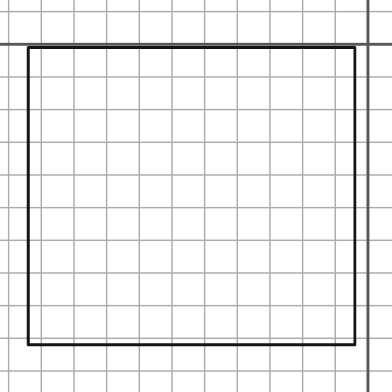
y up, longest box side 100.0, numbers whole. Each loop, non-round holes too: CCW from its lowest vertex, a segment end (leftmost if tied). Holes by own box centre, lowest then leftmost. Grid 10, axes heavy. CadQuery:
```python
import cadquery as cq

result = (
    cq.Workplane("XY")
    .moveTo(-104.0, -92.0)
    .lineTo(-4.0, -92.0)
    .lineTo(-4.0, -1.0)
    .lineTo(-104.0, -1.0)
    .close()
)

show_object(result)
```